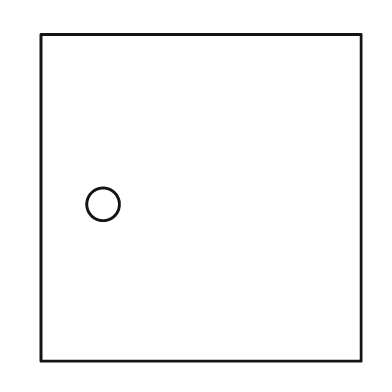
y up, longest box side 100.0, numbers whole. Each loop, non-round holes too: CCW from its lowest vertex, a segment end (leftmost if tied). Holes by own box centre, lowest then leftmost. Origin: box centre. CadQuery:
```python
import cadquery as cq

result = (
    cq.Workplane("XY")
    .moveTo(-49.0, -50.0)
    .lineTo(49.0, -50.0)
    .lineTo(49.0, 50.0)
    .lineTo(-49.0, 50.0)
    .close()
    .moveTo(-30.0, -2.0)
    .circle(5.0)
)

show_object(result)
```